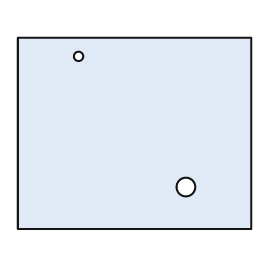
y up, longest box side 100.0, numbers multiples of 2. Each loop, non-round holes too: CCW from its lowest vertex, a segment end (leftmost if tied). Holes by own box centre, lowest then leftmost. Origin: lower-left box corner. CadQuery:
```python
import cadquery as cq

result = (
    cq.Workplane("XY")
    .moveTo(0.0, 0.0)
    .lineTo(100.0, 0.0)
    .lineTo(100.0, 82.0)
    .lineTo(0.0, 82.0)
    .close()
    .moveTo(72.0, 18.0)
    .circle(4.0)
    .moveTo(26.0, 74.0)
    .circle(2.0)
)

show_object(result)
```